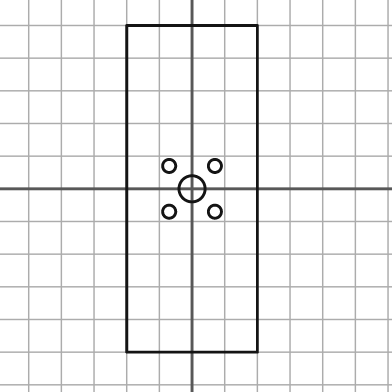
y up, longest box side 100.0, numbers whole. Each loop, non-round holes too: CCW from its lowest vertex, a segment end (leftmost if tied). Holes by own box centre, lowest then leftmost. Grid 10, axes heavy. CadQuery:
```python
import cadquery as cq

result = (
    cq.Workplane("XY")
    .moveTo(-20.0, -50.0)
    .lineTo(20.0, -50.0)
    .lineTo(20.0, 50.0)
    .lineTo(-20.0, 50.0)
    .close()
    .moveTo(-7.0, -7.0)
    .circle(2.0)
    .moveTo(7.0, -7.0)
    .circle(2.0)
    .moveTo(0.0, 0.0)
    .circle(4.0)
    .moveTo(-7.0, 7.0)
    .circle(2.0)
    .moveTo(7.0, 7.0)
    .circle(2.0)
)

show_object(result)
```